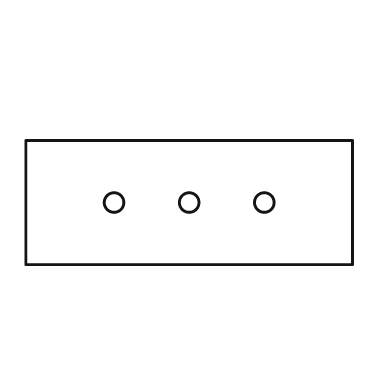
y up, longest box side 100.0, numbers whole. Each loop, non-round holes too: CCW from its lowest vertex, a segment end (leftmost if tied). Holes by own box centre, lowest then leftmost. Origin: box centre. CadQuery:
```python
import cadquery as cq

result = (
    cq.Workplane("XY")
    .moveTo(-50.0, -19.0)
    .lineTo(50.0, -19.0)
    .lineTo(50.0, 19.0)
    .lineTo(-50.0, 19.0)
    .close()
    .moveTo(-23.0, 0.0)
    .circle(3.0)
    .moveTo(0.0, 0.0)
    .circle(3.0)
    .moveTo(23.0, 0.0)
    .circle(3.0)
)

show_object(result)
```